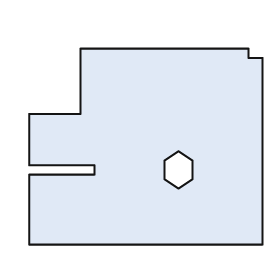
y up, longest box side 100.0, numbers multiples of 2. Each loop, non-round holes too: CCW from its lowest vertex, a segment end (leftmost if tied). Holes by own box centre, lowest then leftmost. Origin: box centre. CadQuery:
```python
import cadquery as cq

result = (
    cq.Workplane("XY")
    .moveTo(-50.0, -42.0)
    .lineTo(50.0, -42.0)
    .lineTo(50.0, 38.0)
    .lineTo(44.0, 38.0)
    .lineTo(44.0, 42.0)
    .lineTo(-28.0, 42.0)
    .lineTo(-28.0, 14.0)
    .lineTo(-50.0, 14.0)
    .lineTo(-50.0, -8.0)
    .lineTo(-22.0, -8.0)
    .lineTo(-22.0, -12.0)
    .lineTo(-50.0, -12.0)
    .close()
    .moveTo(14.0, -18.0)
    .lineTo(20.0, -14.0)
    .lineTo(20.0, -6.0)
    .lineTo(14.0, -2.0)
    .lineTo(8.0, -6.0)
    .lineTo(8.0, -14.0)
    .close()
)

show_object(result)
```